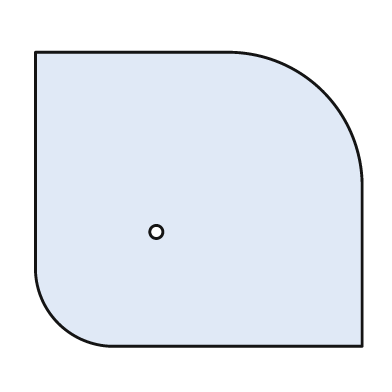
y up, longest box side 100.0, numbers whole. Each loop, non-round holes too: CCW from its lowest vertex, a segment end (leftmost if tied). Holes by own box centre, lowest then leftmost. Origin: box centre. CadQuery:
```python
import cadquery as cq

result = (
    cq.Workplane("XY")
    .moveTo(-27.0, -45.0)
    .lineTo(50.0, -45.0)
    .lineTo(50.0, 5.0)
    .threePointArc((38.0, 33.0), (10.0, 45.0))
    .lineTo(-50.0, 45.0)
    .lineTo(-50.0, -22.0)
    .threePointArc((-43.0, -38.0), (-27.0, -45.0))
    .close()
    .moveTo(-13.0, -10.0)
    .circle(2.0)
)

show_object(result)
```